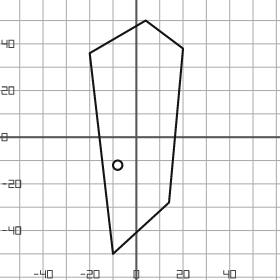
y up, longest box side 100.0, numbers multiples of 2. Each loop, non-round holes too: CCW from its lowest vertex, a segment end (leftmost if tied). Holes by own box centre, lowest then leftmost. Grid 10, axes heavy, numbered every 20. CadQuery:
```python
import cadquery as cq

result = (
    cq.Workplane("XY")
    .moveTo(-10.0, -50.0)
    .lineTo(14.0, -28.0)
    .lineTo(20.0, 38.0)
    .lineTo(4.0, 50.0)
    .lineTo(-20.0, 36.0)
    .close()
    .moveTo(-8.0, -12.0)
    .circle(2.0)
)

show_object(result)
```